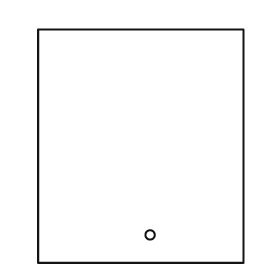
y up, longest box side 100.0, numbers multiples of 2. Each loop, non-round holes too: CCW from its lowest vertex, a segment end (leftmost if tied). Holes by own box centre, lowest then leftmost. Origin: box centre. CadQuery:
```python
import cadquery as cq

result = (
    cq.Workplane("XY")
    .moveTo(-44.0, -50.0)
    .lineTo(44.0, -50.0)
    .lineTo(44.0, 50.0)
    .lineTo(-44.0, 50.0)
    .close()
    .moveTo(4.0, -38.0)
    .circle(2.0)
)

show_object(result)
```